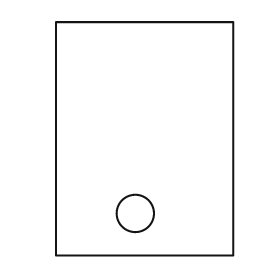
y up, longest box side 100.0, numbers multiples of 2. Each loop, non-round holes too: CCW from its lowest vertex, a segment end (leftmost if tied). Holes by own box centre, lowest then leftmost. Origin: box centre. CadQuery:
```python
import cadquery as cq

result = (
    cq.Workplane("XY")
    .moveTo(-38.0, -50.0)
    .lineTo(38.0, -50.0)
    .lineTo(38.0, 50.0)
    .lineTo(-38.0, 50.0)
    .close()
    .moveTo(-4.0, -32.0)
    .circle(8.0)
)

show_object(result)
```